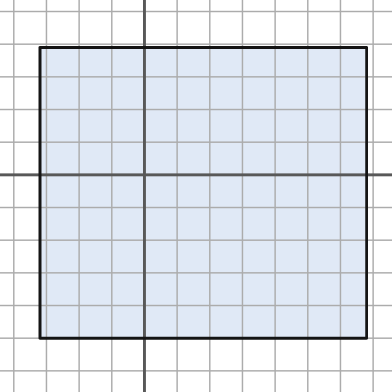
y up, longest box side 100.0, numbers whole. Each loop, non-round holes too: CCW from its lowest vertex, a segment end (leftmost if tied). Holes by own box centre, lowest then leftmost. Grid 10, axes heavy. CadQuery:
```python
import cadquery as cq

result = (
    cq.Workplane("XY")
    .moveTo(-32.0, -50.0)
    .lineTo(68.0, -50.0)
    .lineTo(68.0, 39.0)
    .lineTo(-32.0, 39.0)
    .close()
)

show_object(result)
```